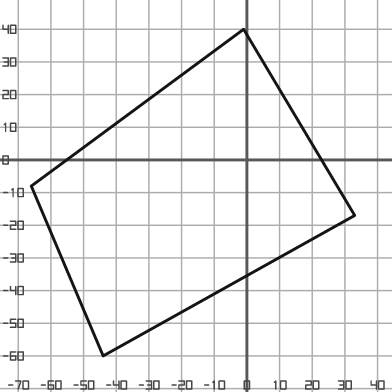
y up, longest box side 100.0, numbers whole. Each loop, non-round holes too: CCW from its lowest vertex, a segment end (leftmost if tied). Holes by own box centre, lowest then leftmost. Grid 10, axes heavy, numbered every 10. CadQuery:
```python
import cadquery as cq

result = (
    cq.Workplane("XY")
    .moveTo(-44.0, -60.0)
    .lineTo(33.0, -17.0)
    .lineTo(-1.0, 40.0)
    .lineTo(-66.0, -8.0)
    .close()
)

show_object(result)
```